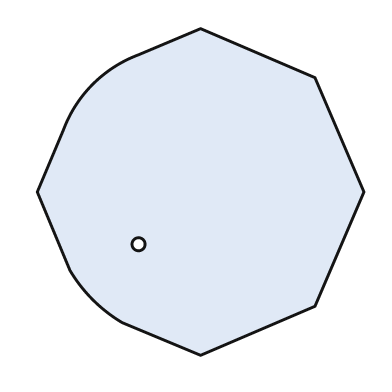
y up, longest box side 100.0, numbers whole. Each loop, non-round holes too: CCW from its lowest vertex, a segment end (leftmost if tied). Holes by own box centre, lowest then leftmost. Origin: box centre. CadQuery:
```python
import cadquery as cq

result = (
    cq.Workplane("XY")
    .moveTo(0.0, -50.0)
    .lineTo(35.0, -35.0)
    .lineTo(50.0, 0.0)
    .lineTo(35.0, 35.0)
    .lineTo(0.0, 50.0)
    .lineTo(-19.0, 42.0)
    .threePointArc((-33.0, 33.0), (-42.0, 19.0))
    .lineTo(-50.0, 0.0)
    .lineTo(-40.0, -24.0)
    .threePointArc((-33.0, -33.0), (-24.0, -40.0))
    .close()
    .moveTo(-19.0, -16.0)
    .circle(2.0)
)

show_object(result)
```